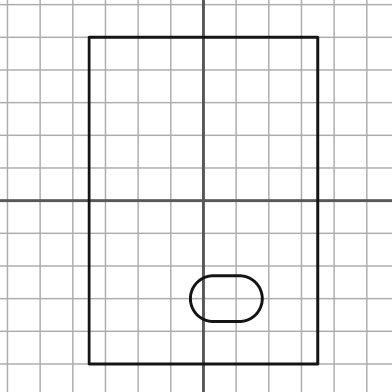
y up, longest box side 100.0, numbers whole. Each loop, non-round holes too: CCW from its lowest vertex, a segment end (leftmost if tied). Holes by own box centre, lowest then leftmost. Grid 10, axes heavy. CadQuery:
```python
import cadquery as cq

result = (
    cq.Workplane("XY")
    .moveTo(-35.0, -50.0)
    .lineTo(35.0, -50.0)
    .lineTo(35.0, 50.0)
    .lineTo(-35.0, 50.0)
    .close()
    .moveTo(3.0, -37.0)
    .lineTo(11.0, -37.0)
    .threePointArc((18.0, -30.0), (11.0, -23.0))
    .lineTo(3.0, -23.0)
    .threePointArc((-4.0, -30.0), (3.0, -37.0))
    .close()
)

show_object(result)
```